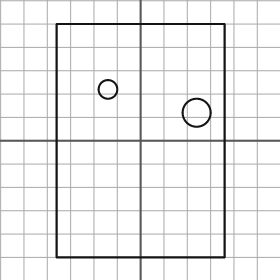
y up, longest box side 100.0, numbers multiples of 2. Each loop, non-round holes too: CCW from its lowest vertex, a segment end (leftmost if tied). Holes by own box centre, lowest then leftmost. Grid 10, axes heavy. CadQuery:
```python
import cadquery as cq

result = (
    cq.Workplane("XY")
    .moveTo(-36.0, -50.0)
    .lineTo(36.0, -50.0)
    .lineTo(36.0, 50.0)
    .lineTo(-36.0, 50.0)
    .close()
    .moveTo(24.0, 12.0)
    .circle(6.0)
    .moveTo(-14.0, 22.0)
    .circle(4.0)
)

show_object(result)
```